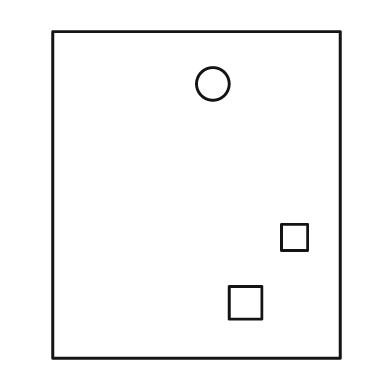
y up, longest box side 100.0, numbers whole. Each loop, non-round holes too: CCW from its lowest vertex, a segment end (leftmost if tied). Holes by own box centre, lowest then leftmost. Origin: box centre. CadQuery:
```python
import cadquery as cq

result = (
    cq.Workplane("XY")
    .moveTo(-44.0, -50.0)
    .lineTo(44.0, -50.0)
    .lineTo(44.0, 50.0)
    .lineTo(-44.0, 50.0)
    .close()
    .moveTo(10.0, -38.0)
    .lineTo(20.0, -38.0)
    .lineTo(20.0, -28.0)
    .lineTo(10.0, -28.0)
    .close()
    .moveTo(26.0, -17.0)
    .lineTo(34.0, -17.0)
    .lineTo(34.0, -9.0)
    .lineTo(26.0, -9.0)
    .close()
    .moveTo(5.0, 34.0)
    .circle(5.0)
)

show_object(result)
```